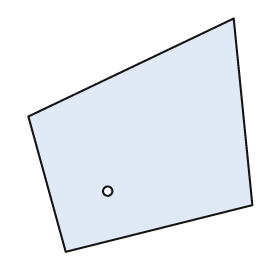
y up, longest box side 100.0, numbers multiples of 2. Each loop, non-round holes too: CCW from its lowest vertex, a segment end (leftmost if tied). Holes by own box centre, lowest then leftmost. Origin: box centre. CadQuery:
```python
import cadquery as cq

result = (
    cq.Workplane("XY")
    .moveTo(-32.0, -50.0)
    .lineTo(48.0, -30.0)
    .lineTo(40.0, 50.0)
    .lineTo(-48.0, 8.0)
    .close()
    .moveTo(-14.0, -24.0)
    .circle(2.0)
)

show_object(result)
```